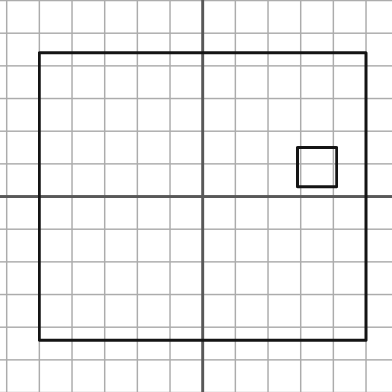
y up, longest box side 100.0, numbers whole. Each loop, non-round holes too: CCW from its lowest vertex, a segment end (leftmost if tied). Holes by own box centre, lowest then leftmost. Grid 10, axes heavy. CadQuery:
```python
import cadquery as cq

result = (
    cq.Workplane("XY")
    .moveTo(-50.0, -44.0)
    .lineTo(50.0, -44.0)
    .lineTo(50.0, 44.0)
    .lineTo(-50.0, 44.0)
    .close()
    .moveTo(29.0, 3.0)
    .lineTo(41.0, 3.0)
    .lineTo(41.0, 15.0)
    .lineTo(29.0, 15.0)
    .close()
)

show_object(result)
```